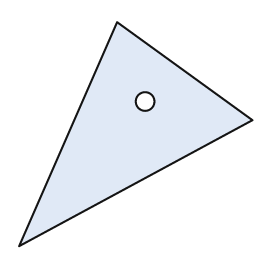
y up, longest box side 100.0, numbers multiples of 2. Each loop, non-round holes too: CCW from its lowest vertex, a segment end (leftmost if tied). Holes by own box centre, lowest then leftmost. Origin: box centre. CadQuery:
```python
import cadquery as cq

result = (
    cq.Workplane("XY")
    .moveTo(-50.0, -48.0)
    .lineTo(50.0, 6.0)
    .lineTo(-8.0, 48.0)
    .close()
    .moveTo(4.0, 14.0)
    .circle(4.0)
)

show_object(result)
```